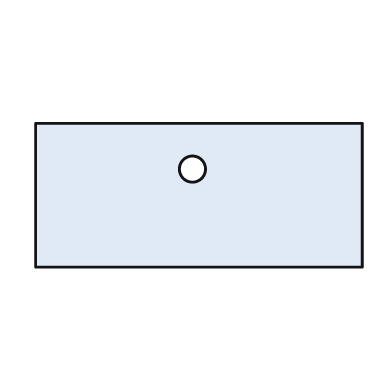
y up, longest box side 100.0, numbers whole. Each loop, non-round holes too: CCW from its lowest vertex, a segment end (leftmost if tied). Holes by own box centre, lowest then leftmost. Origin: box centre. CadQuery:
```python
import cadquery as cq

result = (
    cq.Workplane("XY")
    .moveTo(-50.0, -22.0)
    .lineTo(50.0, -22.0)
    .lineTo(50.0, 22.0)
    .lineTo(-50.0, 22.0)
    .close()
    .moveTo(-2.0, 8.0)
    .circle(4.0)
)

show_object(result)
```